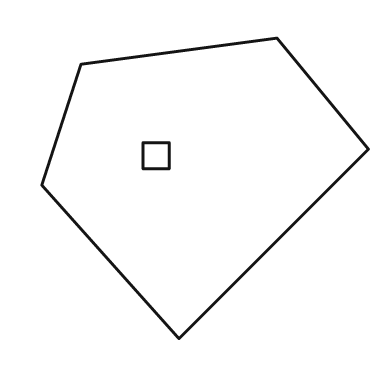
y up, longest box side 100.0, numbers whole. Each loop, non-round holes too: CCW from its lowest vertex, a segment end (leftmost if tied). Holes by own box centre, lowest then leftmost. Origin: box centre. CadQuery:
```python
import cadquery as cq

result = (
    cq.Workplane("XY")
    .moveTo(-8.0, -46.0)
    .lineTo(50.0, 12.0)
    .lineTo(22.0, 46.0)
    .lineTo(-38.0, 38.0)
    .lineTo(-50.0, 1.0)
    .close()
    .moveTo(-19.0, 6.0)
    .lineTo(-11.0, 6.0)
    .lineTo(-11.0, 14.0)
    .lineTo(-19.0, 14.0)
    .close()
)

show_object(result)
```